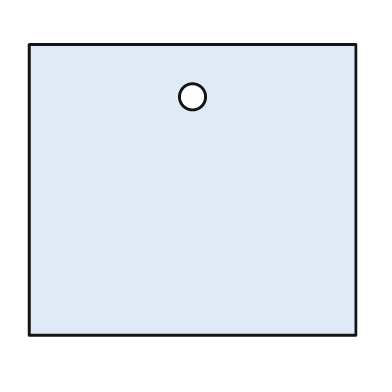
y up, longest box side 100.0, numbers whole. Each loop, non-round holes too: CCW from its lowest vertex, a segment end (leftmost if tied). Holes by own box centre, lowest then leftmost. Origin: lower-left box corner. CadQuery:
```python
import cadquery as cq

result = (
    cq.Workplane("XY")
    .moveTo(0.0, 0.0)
    .lineTo(100.0, 0.0)
    .lineTo(100.0, 89.0)
    .lineTo(0.0, 89.0)
    .close()
    .moveTo(50.0, 73.0)
    .circle(4.0)
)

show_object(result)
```